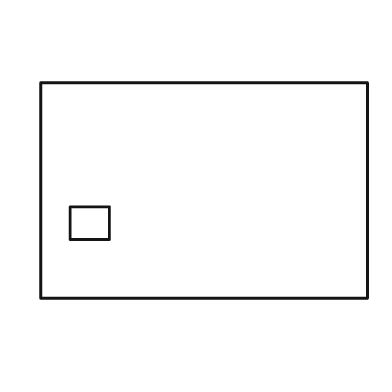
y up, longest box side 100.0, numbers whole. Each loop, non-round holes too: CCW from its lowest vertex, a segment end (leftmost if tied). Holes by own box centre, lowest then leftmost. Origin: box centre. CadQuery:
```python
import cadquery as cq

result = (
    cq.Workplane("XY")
    .moveTo(-50.0, -33.0)
    .lineTo(50.0, -33.0)
    .lineTo(50.0, 33.0)
    .lineTo(-50.0, 33.0)
    .close()
    .moveTo(-41.0, -15.0)
    .lineTo(-29.0, -15.0)
    .lineTo(-29.0, -5.0)
    .lineTo(-41.0, -5.0)
    .close()
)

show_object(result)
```